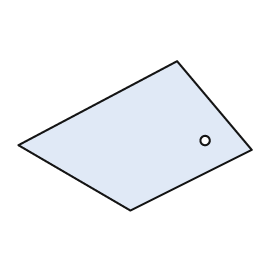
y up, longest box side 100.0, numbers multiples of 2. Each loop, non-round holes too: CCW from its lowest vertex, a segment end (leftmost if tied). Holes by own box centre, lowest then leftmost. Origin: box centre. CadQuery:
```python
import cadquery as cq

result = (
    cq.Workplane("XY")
    .moveTo(-2.0, -32.0)
    .lineTo(50.0, -6.0)
    .lineTo(18.0, 32.0)
    .lineTo(-50.0, -4.0)
    .close()
    .moveTo(30.0, -2.0)
    .circle(2.0)
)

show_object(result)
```